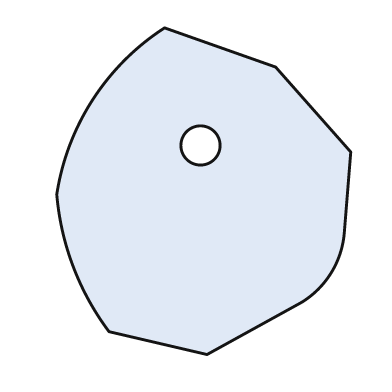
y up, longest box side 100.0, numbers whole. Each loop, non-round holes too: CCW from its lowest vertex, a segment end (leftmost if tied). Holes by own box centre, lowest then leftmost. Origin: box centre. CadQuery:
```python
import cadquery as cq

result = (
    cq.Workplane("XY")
    .moveTo(1.0, -50.0)
    .lineTo(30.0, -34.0)
    .threePointArc((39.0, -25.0), (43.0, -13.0))
    .lineTo(45.0, 12.0)
    .lineTo(22.0, 38.0)
    .lineTo(-12.0, 50.0)
    .threePointArc((-34.0, 28.0), (-45.0, -1.0))
    .threePointArc((-40.0, -23.0), (-29.0, -43.0))
    .close()
    .moveTo(-1.0, 14.0)
    .circle(6.0)
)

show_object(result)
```